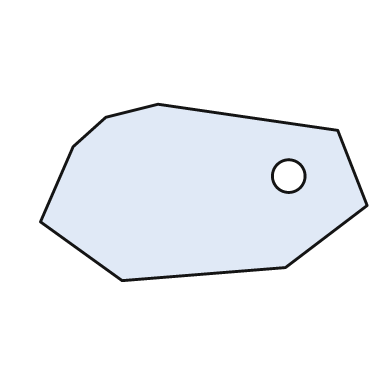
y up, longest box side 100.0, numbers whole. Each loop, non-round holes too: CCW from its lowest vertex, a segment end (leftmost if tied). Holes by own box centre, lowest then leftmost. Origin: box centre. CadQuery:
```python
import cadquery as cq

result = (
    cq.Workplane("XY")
    .moveTo(-25.0, -27.0)
    .lineTo(25.0, -23.0)
    .lineTo(50.0, -4.0)
    .lineTo(41.0, 19.0)
    .lineTo(-14.0, 27.0)
    .lineTo(-30.0, 23.0)
    .lineTo(-40.0, 14.0)
    .lineTo(-50.0, -9.0)
    .close()
    .moveTo(26.0, 5.0)
    .circle(5.0)
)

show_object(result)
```